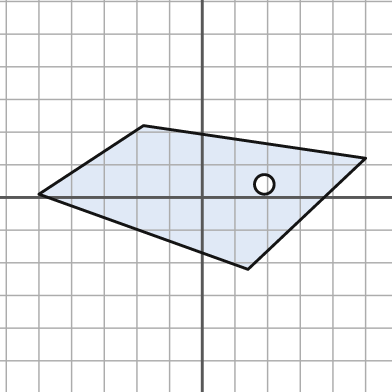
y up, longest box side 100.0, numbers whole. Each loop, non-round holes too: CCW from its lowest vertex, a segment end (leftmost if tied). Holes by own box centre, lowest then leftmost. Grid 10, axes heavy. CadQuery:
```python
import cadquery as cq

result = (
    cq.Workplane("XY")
    .moveTo(14.0, -22.0)
    .lineTo(50.0, 12.0)
    .lineTo(-18.0, 22.0)
    .lineTo(-50.0, 1.0)
    .close()
    .moveTo(19.0, 4.0)
    .circle(3.0)
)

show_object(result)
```